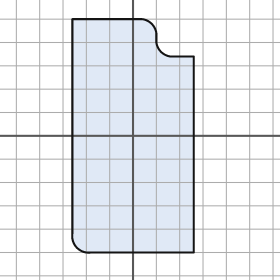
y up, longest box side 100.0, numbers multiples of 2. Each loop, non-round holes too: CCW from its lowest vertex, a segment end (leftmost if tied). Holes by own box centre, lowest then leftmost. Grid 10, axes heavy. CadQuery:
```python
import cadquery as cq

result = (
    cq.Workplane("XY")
    .moveTo(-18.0, -50.0)
    .lineTo(26.0, -50.0)
    .lineTo(26.0, 34.0)
    .lineTo(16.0, 34.0)
    .threePointArc((12.0, 36.0), (10.0, 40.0))
    .lineTo(10.0, 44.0)
    .threePointArc((8.0, 48.0), (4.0, 50.0))
    .lineTo(-26.0, 50.0)
    .lineTo(-26.0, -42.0)
    .threePointArc((-24.0, -48.0), (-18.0, -50.0))
    .close()
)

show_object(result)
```